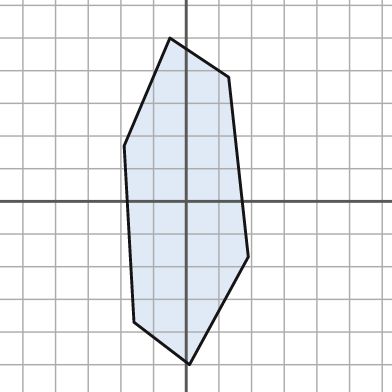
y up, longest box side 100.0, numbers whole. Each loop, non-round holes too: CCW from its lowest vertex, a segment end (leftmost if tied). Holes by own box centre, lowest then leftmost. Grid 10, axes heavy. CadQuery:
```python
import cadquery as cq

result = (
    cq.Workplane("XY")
    .moveTo(1.0, -50.0)
    .lineTo(19.0, -17.0)
    .lineTo(13.0, 38.0)
    .lineTo(-5.0, 50.0)
    .lineTo(-19.0, 17.0)
    .lineTo(-16.0, -37.0)
    .close()
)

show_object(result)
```